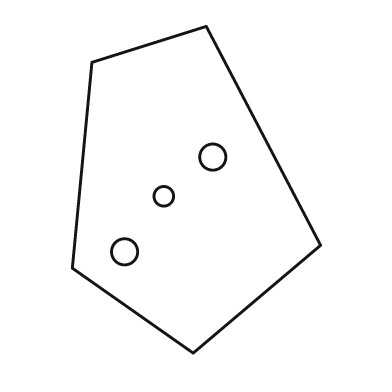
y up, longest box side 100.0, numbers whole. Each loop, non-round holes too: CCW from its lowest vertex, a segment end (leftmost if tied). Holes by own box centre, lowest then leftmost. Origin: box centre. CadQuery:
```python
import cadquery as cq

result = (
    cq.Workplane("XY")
    .moveTo(-1.0, -50.0)
    .lineTo(38.0, -17.0)
    .lineTo(3.0, 50.0)
    .lineTo(-32.0, 39.0)
    .lineTo(-38.0, -24.0)
    .close()
    .moveTo(-22.0, -19.0)
    .circle(4.0)
    .moveTo(-10.0, -2.0)
    .circle(3.0)
    .moveTo(5.0, 10.0)
    .circle(4.0)
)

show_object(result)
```